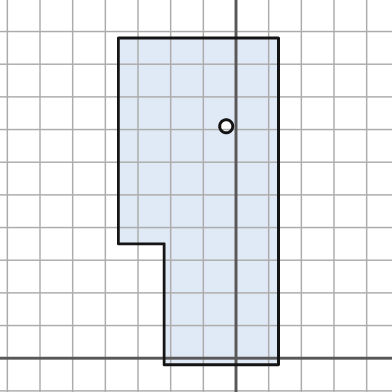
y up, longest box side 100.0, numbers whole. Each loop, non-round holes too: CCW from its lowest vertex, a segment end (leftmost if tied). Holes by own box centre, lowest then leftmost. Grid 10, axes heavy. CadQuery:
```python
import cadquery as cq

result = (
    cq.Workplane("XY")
    .moveTo(-22.0, -2.0)
    .lineTo(13.0, -2.0)
    .lineTo(13.0, 98.0)
    .lineTo(-36.0, 98.0)
    .lineTo(-36.0, 35.0)
    .lineTo(-22.0, 35.0)
    .close()
    .moveTo(-3.0, 71.0)
    .circle(2.0)
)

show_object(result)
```